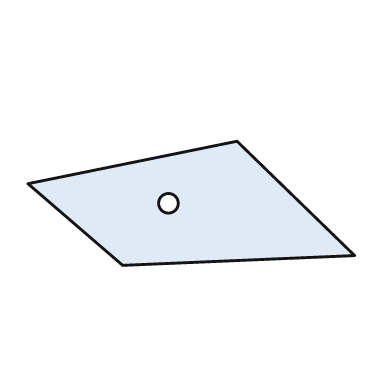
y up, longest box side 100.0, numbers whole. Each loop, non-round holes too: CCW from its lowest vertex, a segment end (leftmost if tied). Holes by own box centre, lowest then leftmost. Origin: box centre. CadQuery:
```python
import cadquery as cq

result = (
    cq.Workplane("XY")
    .moveTo(-21.0, -19.0)
    .lineTo(50.0, -16.0)
    .lineTo(14.0, 19.0)
    .lineTo(-50.0, 6.0)
    .close()
    .moveTo(-7.0, 0.0)
    .circle(3.0)
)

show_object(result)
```